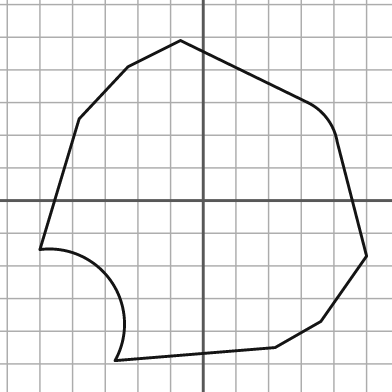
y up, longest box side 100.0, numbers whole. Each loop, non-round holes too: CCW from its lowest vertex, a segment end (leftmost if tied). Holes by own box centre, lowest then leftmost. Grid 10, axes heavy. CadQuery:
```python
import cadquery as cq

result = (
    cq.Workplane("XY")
    .moveTo(-27.0, -49.0)
    .lineTo(22.0, -45.0)
    .lineTo(36.0, -37.0)
    .lineTo(50.0, -17.0)
    .lineTo(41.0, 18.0)
    .threePointArc((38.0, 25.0), (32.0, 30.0))
    .lineTo(-7.0, 49.0)
    .lineTo(-23.0, 41.0)
    .lineTo(-38.0, 25.0)
    .lineTo(-50.0, -15.0)
    .threePointArc((-28.0, -25.0), (-27.0, -49.0))
    .close()
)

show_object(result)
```